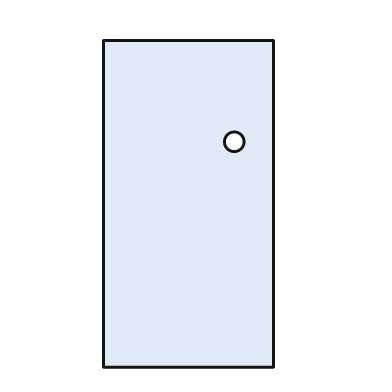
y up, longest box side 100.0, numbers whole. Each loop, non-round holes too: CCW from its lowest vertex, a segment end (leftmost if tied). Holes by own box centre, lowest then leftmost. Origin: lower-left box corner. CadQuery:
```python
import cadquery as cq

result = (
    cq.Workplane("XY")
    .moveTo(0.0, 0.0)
    .lineTo(52.0, 0.0)
    .lineTo(52.0, 100.0)
    .lineTo(0.0, 100.0)
    .close()
    .moveTo(40.0, 69.0)
    .circle(3.0)
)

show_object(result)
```